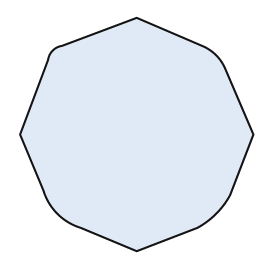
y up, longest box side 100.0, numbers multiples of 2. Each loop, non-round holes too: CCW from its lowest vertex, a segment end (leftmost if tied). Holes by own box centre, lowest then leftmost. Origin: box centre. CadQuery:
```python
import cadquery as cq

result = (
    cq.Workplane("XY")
    .moveTo(0.0, -50.0)
    .lineTo(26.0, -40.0)
    .threePointArc((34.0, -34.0), (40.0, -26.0))
    .lineTo(50.0, 0.0)
    .lineTo(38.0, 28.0)
    .threePointArc((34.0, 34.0), (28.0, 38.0))
    .lineTo(0.0, 50.0)
    .lineTo(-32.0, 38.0)
    .threePointArc((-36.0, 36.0), (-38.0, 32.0))
    .lineTo(-50.0, 0.0)
    .lineTo(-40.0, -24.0)
    .threePointArc((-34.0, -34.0), (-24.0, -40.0))
    .close()
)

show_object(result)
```